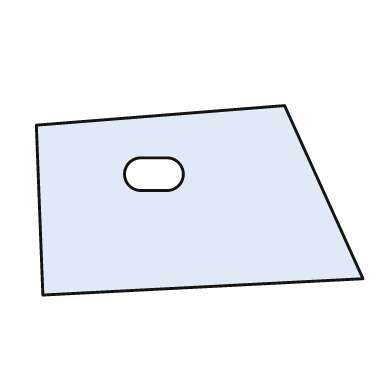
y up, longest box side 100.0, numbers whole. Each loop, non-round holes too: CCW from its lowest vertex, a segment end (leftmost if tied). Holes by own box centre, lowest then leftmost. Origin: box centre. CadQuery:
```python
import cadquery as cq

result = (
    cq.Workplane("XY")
    .moveTo(-48.0, -29.0)
    .lineTo(50.0, -24.0)
    .lineTo(26.0, 29.0)
    .lineTo(-50.0, 23.0)
    .close()
    .moveTo(-18.0, 3.0)
    .lineTo(-10.0, 3.0)
    .threePointArc((-5.0, 8.0), (-10.0, 13.0))
    .lineTo(-18.0, 13.0)
    .threePointArc((-23.0, 8.0), (-18.0, 3.0))
    .close()
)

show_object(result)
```